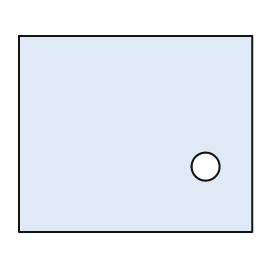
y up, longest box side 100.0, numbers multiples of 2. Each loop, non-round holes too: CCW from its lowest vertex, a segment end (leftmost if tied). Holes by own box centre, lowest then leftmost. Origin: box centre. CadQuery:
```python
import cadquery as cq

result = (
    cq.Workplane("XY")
    .moveTo(-50.0, -42.0)
    .lineTo(50.0, -42.0)
    .lineTo(50.0, 42.0)
    .lineTo(-50.0, 42.0)
    .close()
    .moveTo(30.0, -14.0)
    .circle(6.0)
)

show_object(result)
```